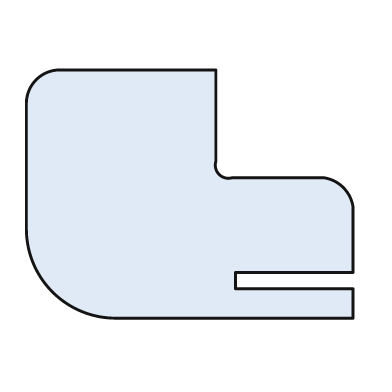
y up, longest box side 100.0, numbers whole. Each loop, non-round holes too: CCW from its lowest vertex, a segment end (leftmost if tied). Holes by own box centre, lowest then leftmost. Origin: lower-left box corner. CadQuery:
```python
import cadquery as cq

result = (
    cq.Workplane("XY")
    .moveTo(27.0, 0.0)
    .lineTo(100.0, 0.0)
    .lineTo(100.0, 9.0)
    .lineTo(64.0, 9.0)
    .lineTo(64.0, 14.0)
    .lineTo(100.0, 14.0)
    .lineTo(100.0, 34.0)
    .threePointArc((97.0, 40.0), (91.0, 43.0))
    .lineTo(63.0, 43.0)
    .threePointArc((59.0, 44.0), (58.0, 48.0))
    .lineTo(58.0, 76.0)
    .lineTo(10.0, 76.0)
    .threePointArc((3.0, 73.0), (0.0, 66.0))
    .lineTo(0.0, 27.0)
    .threePointArc((8.0, 8.0), (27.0, 0.0))
    .close()
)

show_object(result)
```